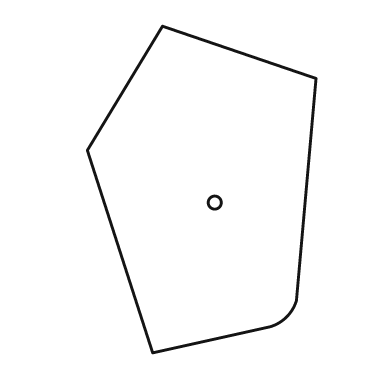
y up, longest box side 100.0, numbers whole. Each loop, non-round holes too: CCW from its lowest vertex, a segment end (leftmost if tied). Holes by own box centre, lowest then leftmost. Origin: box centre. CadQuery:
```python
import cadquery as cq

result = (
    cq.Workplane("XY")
    .moveTo(-15.0, -50.0)
    .lineTo(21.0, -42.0)
    .threePointArc((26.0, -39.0), (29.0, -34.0))
    .lineTo(35.0, 34.0)
    .lineTo(-12.0, 50.0)
    .lineTo(-35.0, 12.0)
    .close()
    .moveTo(4.0, -4.0)
    .circle(2.0)
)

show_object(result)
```